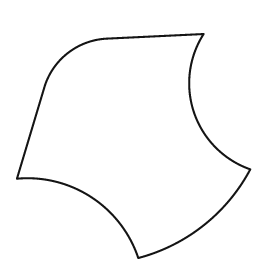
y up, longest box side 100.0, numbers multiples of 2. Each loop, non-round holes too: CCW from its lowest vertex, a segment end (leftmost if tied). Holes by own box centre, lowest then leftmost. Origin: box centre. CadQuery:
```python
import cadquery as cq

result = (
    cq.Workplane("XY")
    .moveTo(2.0, -48.0)
    .threePointArc((30.0, -34.0), (50.0, -10.0))
    .threePointArc((26.0, 14.0), (30.0, 48.0))
    .lineTo(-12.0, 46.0)
    .threePointArc((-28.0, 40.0), (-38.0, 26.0))
    .lineTo(-50.0, -14.0)
    .threePointArc((-18.0, -22.0), (2.0, -48.0))
    .close()
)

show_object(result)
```